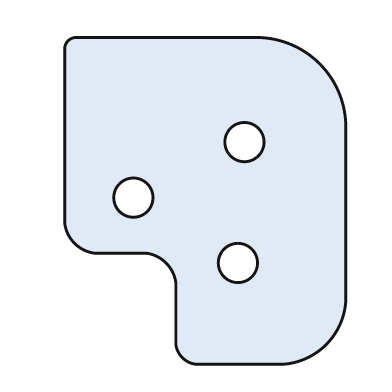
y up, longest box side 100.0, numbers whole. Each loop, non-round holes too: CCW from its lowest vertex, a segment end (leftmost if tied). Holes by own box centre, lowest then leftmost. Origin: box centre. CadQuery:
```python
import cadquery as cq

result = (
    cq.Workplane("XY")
    .moveTo(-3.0, -50.0)
    .lineTo(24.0, -50.0)
    .threePointArc((37.0, -44.0), (43.0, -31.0))
    .lineTo(43.0, 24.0)
    .threePointArc((35.0, 42.0), (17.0, 50.0))
    .lineTo(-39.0, 50.0)
    .threePointArc((-42.0, 49.0), (-43.0, 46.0))
    .lineTo(-43.0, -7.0)
    .threePointArc((-40.0, -13.0), (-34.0, -16.0))
    .lineTo(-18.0, -16.0)
    .threePointArc((-12.0, -19.0), (-9.0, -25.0))
    .lineTo(-9.0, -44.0)
    .threePointArc((-7.0, -48.0), (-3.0, -50.0))
    .close()
    .moveTo(10.0, -19.0)
    .circle(6.0)
    .moveTo(-22.0, 1.0)
    .circle(6.0)
    .moveTo(12.0, 18.0)
    .circle(6.0)
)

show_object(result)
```